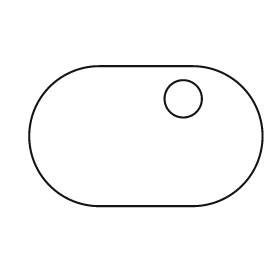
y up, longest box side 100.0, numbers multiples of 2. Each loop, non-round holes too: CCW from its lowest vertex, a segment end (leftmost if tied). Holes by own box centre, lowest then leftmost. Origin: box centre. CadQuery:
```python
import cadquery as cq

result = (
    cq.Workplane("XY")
    .moveTo(-20.0, -30.0)
    .lineTo(20.0, -30.0)
    .threePointArc((50.0, 0.0), (20.0, 30.0))
    .lineTo(-20.0, 30.0)
    .threePointArc((-50.0, 0.0), (-20.0, -30.0))
    .close()
    .moveTo(16.0, 16.0)
    .circle(8.0)
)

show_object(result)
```